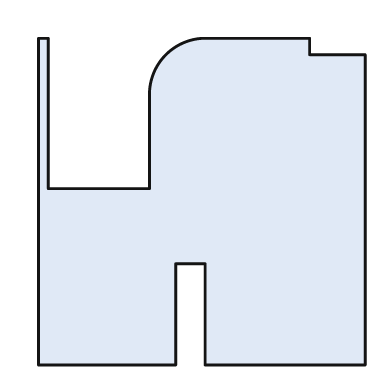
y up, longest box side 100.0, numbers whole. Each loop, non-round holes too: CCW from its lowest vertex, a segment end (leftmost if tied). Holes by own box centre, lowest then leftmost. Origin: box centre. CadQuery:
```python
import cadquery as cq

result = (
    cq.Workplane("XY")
    .moveTo(-50.0, -50.0)
    .lineTo(-8.0, -50.0)
    .lineTo(-8.0, -19.0)
    .lineTo(1.0, -19.0)
    .lineTo(1.0, -50.0)
    .lineTo(50.0, -50.0)
    .lineTo(50.0, 45.0)
    .lineTo(33.0, 45.0)
    .lineTo(33.0, 50.0)
    .lineTo(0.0, 50.0)
    .threePointArc((-11.0, 45.0), (-16.0, 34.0))
    .lineTo(-16.0, 4.0)
    .lineTo(-47.0, 4.0)
    .lineTo(-47.0, 50.0)
    .lineTo(-50.0, 50.0)
    .close()
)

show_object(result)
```